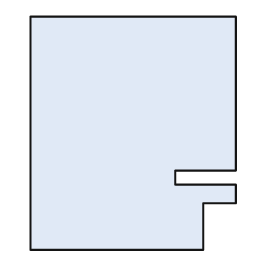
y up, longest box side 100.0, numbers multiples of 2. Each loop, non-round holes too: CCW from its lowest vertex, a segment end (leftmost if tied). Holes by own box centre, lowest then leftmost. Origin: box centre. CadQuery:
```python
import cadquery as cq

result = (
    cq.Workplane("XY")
    .moveTo(-44.0, -50.0)
    .lineTo(30.0, -50.0)
    .lineTo(30.0, -30.0)
    .lineTo(44.0, -30.0)
    .lineTo(44.0, -22.0)
    .lineTo(18.0, -22.0)
    .lineTo(18.0, -16.0)
    .lineTo(44.0, -16.0)
    .lineTo(44.0, 50.0)
    .lineTo(-44.0, 50.0)
    .close()
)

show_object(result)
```